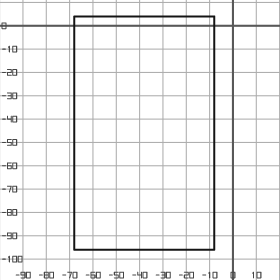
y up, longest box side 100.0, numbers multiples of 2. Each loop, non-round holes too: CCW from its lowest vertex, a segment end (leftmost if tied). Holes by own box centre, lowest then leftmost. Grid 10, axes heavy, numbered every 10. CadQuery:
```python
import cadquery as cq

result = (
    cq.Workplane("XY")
    .moveTo(-68.0, -96.0)
    .lineTo(-8.0, -96.0)
    .lineTo(-8.0, 4.0)
    .lineTo(-68.0, 4.0)
    .close()
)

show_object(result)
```